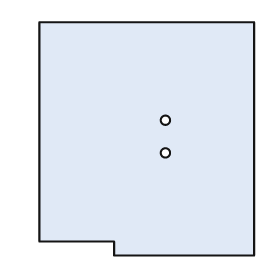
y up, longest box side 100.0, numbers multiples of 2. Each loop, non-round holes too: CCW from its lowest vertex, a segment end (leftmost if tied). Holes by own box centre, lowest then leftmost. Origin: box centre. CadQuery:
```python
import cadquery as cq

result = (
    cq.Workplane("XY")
    .moveTo(-14.0, -50.0)
    .lineTo(46.0, -50.0)
    .lineTo(46.0, 50.0)
    .lineTo(-46.0, 50.0)
    .lineTo(-46.0, -44.0)
    .lineTo(-14.0, -44.0)
    .close()
    .moveTo(8.0, -6.0)
    .circle(2.0)
    .moveTo(8.0, 8.0)
    .circle(2.0)
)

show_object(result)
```